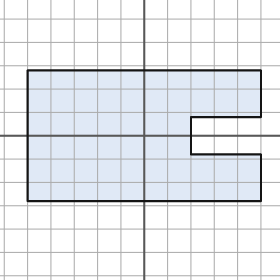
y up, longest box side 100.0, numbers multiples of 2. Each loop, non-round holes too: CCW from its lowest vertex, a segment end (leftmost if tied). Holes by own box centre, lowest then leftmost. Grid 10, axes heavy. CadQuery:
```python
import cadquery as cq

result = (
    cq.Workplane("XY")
    .moveTo(-50.0, -28.0)
    .lineTo(50.0, -28.0)
    .lineTo(50.0, -8.0)
    .lineTo(20.0, -8.0)
    .lineTo(20.0, 8.0)
    .lineTo(50.0, 8.0)
    .lineTo(50.0, 28.0)
    .lineTo(-50.0, 28.0)
    .close()
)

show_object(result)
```